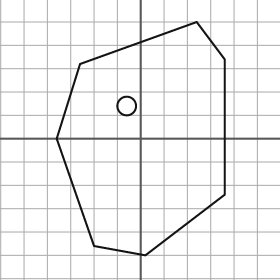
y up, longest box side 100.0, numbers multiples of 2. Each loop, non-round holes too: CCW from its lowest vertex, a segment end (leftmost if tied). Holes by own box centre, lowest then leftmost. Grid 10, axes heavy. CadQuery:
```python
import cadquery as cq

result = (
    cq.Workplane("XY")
    .moveTo(2.0, -50.0)
    .lineTo(36.0, -24.0)
    .lineTo(36.0, 34.0)
    .lineTo(24.0, 50.0)
    .lineTo(-26.0, 32.0)
    .lineTo(-36.0, 0.0)
    .lineTo(-20.0, -46.0)
    .close()
    .moveTo(-6.0, 14.0)
    .circle(4.0)
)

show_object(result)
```